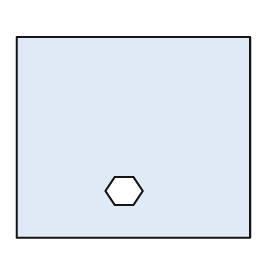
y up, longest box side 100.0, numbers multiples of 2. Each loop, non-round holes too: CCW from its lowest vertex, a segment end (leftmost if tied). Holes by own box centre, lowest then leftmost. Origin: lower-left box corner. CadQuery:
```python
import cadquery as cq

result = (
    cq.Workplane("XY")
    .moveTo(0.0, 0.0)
    .lineTo(100.0, 0.0)
    .lineTo(100.0, 86.0)
    .lineTo(0.0, 86.0)
    .close()
    .moveTo(42.0, 14.0)
    .lineTo(50.0, 14.0)
    .lineTo(54.0, 20.0)
    .lineTo(50.0, 26.0)
    .lineTo(42.0, 26.0)
    .lineTo(38.0, 20.0)
    .close()
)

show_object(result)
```